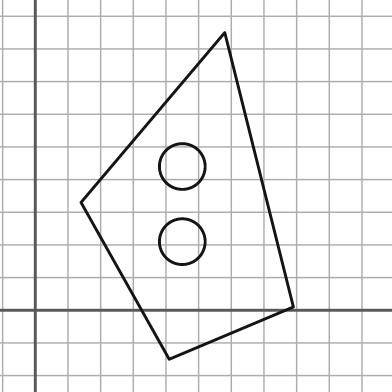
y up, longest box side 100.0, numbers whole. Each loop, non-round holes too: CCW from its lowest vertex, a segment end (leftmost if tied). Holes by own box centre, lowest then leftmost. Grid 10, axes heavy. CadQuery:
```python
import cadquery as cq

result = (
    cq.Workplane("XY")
    .moveTo(41.0, -15.0)
    .lineTo(79.0, 1.0)
    .lineTo(58.0, 85.0)
    .lineTo(14.0, 33.0)
    .close()
    .moveTo(45.0, 21.0)
    .circle(7.0)
    .moveTo(45.0, 44.0)
    .circle(7.0)
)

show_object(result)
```